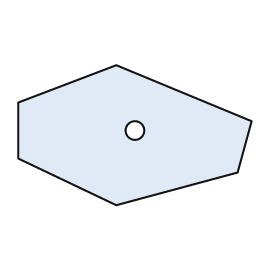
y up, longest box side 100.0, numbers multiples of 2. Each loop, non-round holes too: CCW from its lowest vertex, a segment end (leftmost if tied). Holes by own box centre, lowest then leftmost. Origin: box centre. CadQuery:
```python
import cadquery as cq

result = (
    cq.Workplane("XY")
    .moveTo(-8.0, -30.0)
    .lineTo(44.0, -16.0)
    .lineTo(50.0, 6.0)
    .lineTo(-8.0, 30.0)
    .lineTo(-50.0, 14.0)
    .lineTo(-50.0, -10.0)
    .close()
    .moveTo(0.0, 2.0)
    .circle(4.0)
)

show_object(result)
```